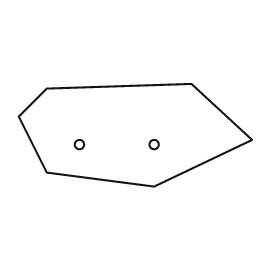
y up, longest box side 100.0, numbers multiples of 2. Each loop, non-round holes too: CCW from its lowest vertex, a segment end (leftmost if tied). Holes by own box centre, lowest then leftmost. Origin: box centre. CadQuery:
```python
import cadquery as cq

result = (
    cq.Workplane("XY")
    .moveTo(8.0, -22.0)
    .lineTo(50.0, -2.0)
    .lineTo(24.0, 22.0)
    .lineTo(-38.0, 20.0)
    .lineTo(-50.0, 8.0)
    .lineTo(-38.0, -16.0)
    .close()
    .moveTo(-24.0, -4.0)
    .circle(2.0)
    .moveTo(8.0, -4.0)
    .circle(2.0)
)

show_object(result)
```